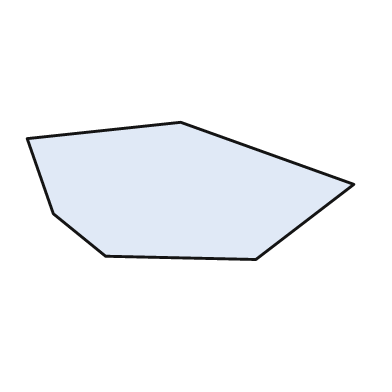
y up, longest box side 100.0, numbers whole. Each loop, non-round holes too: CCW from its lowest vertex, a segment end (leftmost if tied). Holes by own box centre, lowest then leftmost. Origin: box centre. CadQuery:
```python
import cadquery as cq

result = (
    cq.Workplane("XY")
    .moveTo(20.0, -21.0)
    .lineTo(50.0, 2.0)
    .lineTo(-3.0, 21.0)
    .lineTo(-50.0, 16.0)
    .lineTo(-42.0, -7.0)
    .lineTo(-26.0, -20.0)
    .close()
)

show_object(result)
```